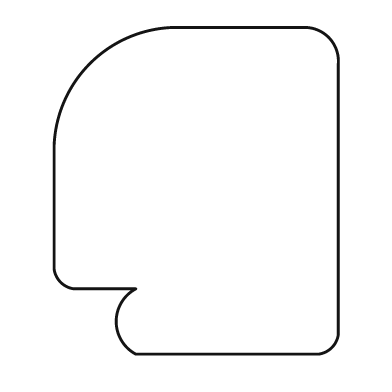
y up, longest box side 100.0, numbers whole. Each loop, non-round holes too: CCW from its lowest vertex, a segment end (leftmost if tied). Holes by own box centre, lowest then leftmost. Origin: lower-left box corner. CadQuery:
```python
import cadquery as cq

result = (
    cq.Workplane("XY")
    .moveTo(25.0, 0.0)
    .lineTo(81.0, 0.0)
    .threePointArc((85.0, 2.0), (87.0, 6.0))
    .lineTo(87.0, 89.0)
    .threePointArc((84.0, 97.0), (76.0, 100.0))
    .lineTo(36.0, 100.0)
    .threePointArc((11.0, 89.0), (0.0, 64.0))
    .lineTo(0.0, 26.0)
    .threePointArc((2.0, 22.0), (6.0, 20.0))
    .lineTo(25.0, 20.0)
    .threePointArc((19.0, 10.0), (25.0, 0.0))
    .close()
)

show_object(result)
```